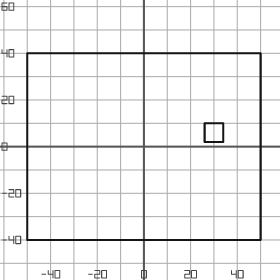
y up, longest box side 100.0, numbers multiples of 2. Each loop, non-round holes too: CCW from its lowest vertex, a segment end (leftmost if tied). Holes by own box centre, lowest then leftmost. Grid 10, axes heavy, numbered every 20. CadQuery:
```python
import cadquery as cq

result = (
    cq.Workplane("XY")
    .moveTo(-50.0, -40.0)
    .lineTo(50.0, -40.0)
    .lineTo(50.0, 40.0)
    .lineTo(-50.0, 40.0)
    .close()
    .moveTo(26.0, 2.0)
    .lineTo(34.0, 2.0)
    .lineTo(34.0, 10.0)
    .lineTo(26.0, 10.0)
    .close()
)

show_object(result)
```